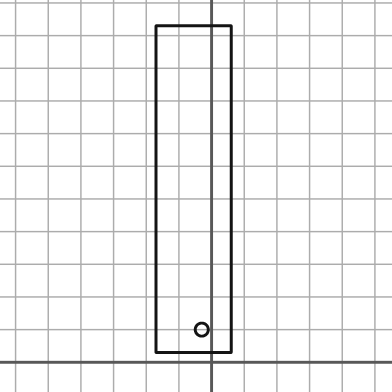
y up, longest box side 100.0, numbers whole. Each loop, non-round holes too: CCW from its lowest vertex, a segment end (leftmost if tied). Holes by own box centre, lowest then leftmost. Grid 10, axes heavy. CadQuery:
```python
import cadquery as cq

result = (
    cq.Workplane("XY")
    .moveTo(-17.0, 3.0)
    .lineTo(6.0, 3.0)
    .lineTo(6.0, 103.0)
    .lineTo(-17.0, 103.0)
    .close()
    .moveTo(-3.0, 10.0)
    .circle(2.0)
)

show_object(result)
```